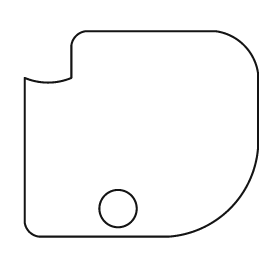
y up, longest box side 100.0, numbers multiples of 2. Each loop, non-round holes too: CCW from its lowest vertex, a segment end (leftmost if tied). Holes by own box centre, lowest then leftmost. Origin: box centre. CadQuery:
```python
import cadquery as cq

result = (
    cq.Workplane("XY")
    .moveTo(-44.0, -44.0)
    .lineTo(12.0, -44.0)
    .threePointArc((38.0, -32.0), (50.0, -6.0))
    .lineTo(50.0, 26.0)
    .threePointArc((44.0, 38.0), (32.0, 44.0))
    .lineTo(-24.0, 44.0)
    .threePointArc((-28.0, 42.0), (-30.0, 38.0))
    .lineTo(-30.0, 24.0)
    .threePointArc((-40.0, 22.0), (-50.0, 24.0))
    .lineTo(-50.0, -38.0)
    .threePointArc((-48.0, -42.0), (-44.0, -44.0))
    .close()
    .moveTo(-10.0, -32.0)
    .circle(8.0)
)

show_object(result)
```